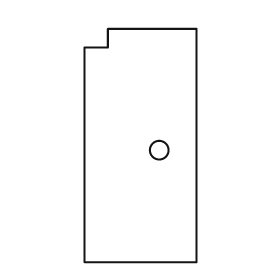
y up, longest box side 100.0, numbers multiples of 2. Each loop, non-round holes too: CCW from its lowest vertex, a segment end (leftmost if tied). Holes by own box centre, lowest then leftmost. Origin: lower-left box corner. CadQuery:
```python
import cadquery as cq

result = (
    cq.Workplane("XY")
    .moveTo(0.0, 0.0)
    .lineTo(48.0, 0.0)
    .lineTo(48.0, 100.0)
    .lineTo(10.0, 100.0)
    .lineTo(10.0, 92.0)
    .lineTo(0.0, 92.0)
    .close()
    .moveTo(32.0, 48.0)
    .circle(4.0)
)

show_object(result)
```